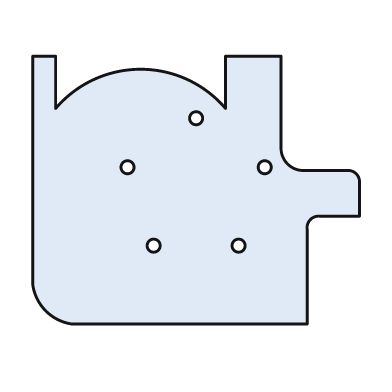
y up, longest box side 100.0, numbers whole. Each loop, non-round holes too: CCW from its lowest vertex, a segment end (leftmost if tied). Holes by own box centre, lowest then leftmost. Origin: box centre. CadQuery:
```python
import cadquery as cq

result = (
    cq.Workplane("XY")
    .moveTo(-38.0, -41.0)
    .lineTo(34.0, -41.0)
    .lineTo(34.0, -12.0)
    .threePointArc((35.0, -9.0), (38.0, -8.0))
    .lineTo(50.0, -8.0)
    .lineTo(50.0, 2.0)
    .threePointArc((49.0, 5.0), (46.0, 6.0))
    .lineTo(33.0, 6.0)
    .threePointArc((28.0, 8.0), (26.0, 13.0))
    .lineTo(26.0, 41.0)
    .lineTo(9.0, 41.0)
    .lineTo(9.0, 25.0)
    .threePointArc((-17.0, 37.0), (-43.0, 25.0))
    .lineTo(-43.0, 41.0)
    .lineTo(-50.0, 41.0)
    .lineTo(-50.0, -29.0)
    .threePointArc((-46.0, -37.0), (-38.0, -41.0))
    .close()
    .moveTo(-13.0, -17.0)
    .circle(2.0)
    .moveTo(13.0, -17.0)
    .circle(2.0)
    .moveTo(-21.0, 7.0)
    .circle(2.0)
    .moveTo(21.0, 7.0)
    .circle(2.0)
    .moveTo(0.0, 22.0)
    .circle(2.0)
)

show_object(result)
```